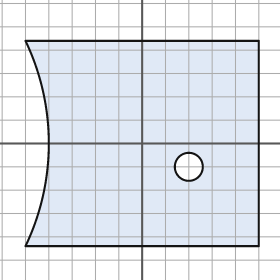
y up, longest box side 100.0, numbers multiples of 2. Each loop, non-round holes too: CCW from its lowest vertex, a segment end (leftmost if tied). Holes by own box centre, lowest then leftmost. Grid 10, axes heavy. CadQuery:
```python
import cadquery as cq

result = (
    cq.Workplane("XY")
    .moveTo(-50.0, -44.0)
    .lineTo(50.0, -44.0)
    .lineTo(50.0, 44.0)
    .lineTo(-50.0, 44.0)
    .threePointArc((-40.0, 0.0), (-50.0, -44.0))
    .close()
    .moveTo(20.0, -10.0)
    .circle(6.0)
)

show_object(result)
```